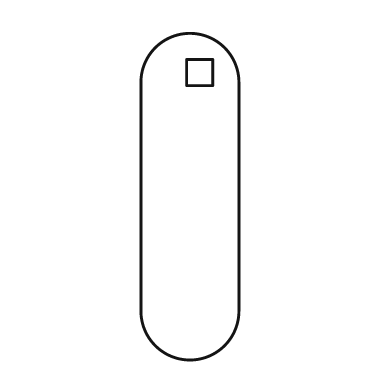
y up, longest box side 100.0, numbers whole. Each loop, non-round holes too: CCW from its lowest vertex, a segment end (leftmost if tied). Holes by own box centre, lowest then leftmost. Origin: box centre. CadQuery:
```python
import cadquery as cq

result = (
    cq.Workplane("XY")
    .moveTo(-15.0, -35.0)
    .threePointArc((0.0, -50.0), (15.0, -35.0))
    .lineTo(15.0, 35.0)
    .threePointArc((0.0, 50.0), (-15.0, 35.0))
    .close()
    .moveTo(-1.0, 34.0)
    .lineTo(7.0, 34.0)
    .lineTo(7.0, 42.0)
    .lineTo(-1.0, 42.0)
    .close()
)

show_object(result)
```